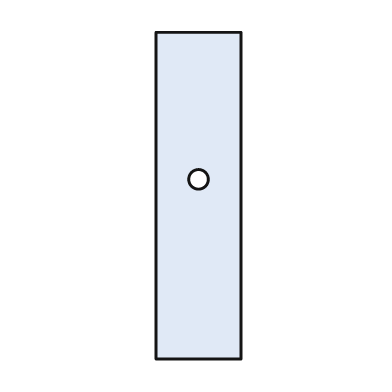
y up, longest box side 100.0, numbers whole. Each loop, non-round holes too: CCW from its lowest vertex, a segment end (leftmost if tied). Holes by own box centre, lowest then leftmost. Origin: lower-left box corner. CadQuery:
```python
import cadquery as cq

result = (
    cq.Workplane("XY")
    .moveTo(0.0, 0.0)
    .lineTo(26.0, 0.0)
    .lineTo(26.0, 100.0)
    .lineTo(0.0, 100.0)
    .close()
    .moveTo(13.0, 55.0)
    .circle(3.0)
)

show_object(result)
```